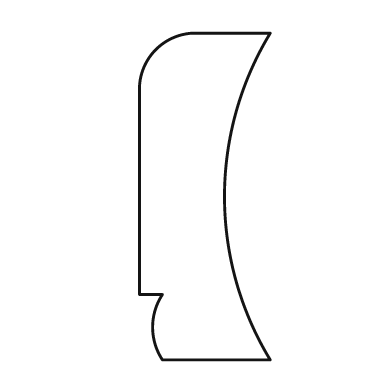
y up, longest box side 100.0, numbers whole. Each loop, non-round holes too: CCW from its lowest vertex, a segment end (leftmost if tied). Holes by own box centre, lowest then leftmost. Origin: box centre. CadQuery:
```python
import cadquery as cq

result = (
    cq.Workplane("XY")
    .moveTo(-13.0, -50.0)
    .lineTo(20.0, -50.0)
    .threePointArc((6.0, 0.0), (20.0, 50.0))
    .lineTo(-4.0, 50.0)
    .threePointArc((-15.0, 45.0), (-20.0, 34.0))
    .lineTo(-20.0, -30.0)
    .lineTo(-13.0, -30.0)
    .threePointArc((-16.0, -40.0), (-13.0, -50.0))
    .close()
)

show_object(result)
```